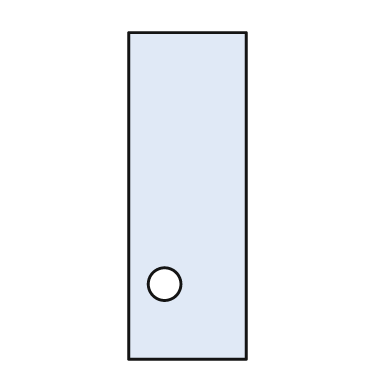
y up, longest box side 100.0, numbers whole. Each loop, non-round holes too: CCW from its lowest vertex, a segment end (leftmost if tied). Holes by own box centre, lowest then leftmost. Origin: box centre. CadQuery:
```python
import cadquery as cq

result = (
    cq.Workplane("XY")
    .moveTo(-18.0, -50.0)
    .lineTo(18.0, -50.0)
    .lineTo(18.0, 50.0)
    .lineTo(-18.0, 50.0)
    .close()
    .moveTo(-7.0, -27.0)
    .circle(5.0)
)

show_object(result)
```